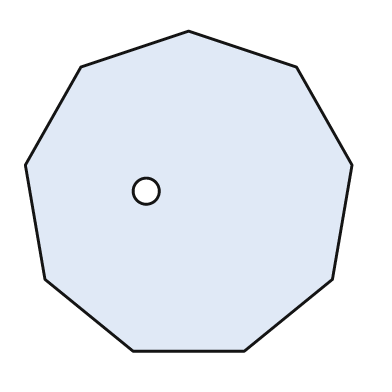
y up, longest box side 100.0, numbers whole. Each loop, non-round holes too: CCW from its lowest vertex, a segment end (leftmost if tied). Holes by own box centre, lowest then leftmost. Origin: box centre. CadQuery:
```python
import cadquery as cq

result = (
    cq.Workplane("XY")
    .moveTo(-17.0, -49.0)
    .lineTo(17.0, -49.0)
    .lineTo(44.0, -27.0)
    .lineTo(50.0, 8.0)
    .lineTo(33.0, 38.0)
    .lineTo(0.0, 49.0)
    .lineTo(-33.0, 38.0)
    .lineTo(-50.0, 8.0)
    .lineTo(-44.0, -27.0)
    .close()
    .moveTo(-13.0, 0.0)
    .circle(4.0)
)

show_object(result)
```